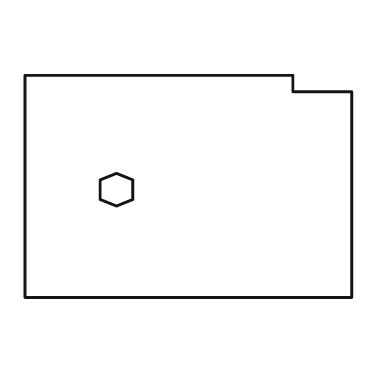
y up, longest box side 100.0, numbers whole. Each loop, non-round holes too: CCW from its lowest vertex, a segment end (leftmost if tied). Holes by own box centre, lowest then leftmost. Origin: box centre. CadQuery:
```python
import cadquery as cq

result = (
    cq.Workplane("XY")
    .moveTo(-50.0, -34.0)
    .lineTo(50.0, -34.0)
    .lineTo(50.0, 29.0)
    .lineTo(32.0, 29.0)
    .lineTo(32.0, 34.0)
    .lineTo(-50.0, 34.0)
    .close()
    .moveTo(-22.0, -6.0)
    .lineTo(-17.0, -4.0)
    .lineTo(-17.0, 2.0)
    .lineTo(-22.0, 4.0)
    .lineTo(-27.0, 2.0)
    .lineTo(-27.0, -4.0)
    .close()
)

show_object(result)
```